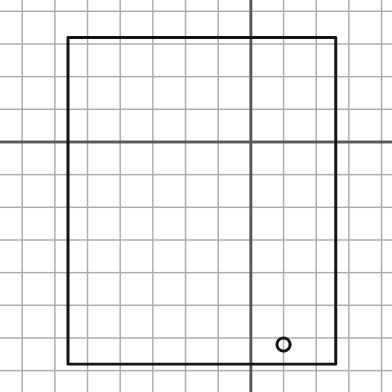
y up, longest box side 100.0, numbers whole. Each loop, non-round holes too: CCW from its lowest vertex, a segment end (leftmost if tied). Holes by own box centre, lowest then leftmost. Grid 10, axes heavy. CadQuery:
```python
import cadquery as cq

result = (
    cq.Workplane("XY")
    .moveTo(-56.0, -68.0)
    .lineTo(26.0, -68.0)
    .lineTo(26.0, 32.0)
    .lineTo(-56.0, 32.0)
    .close()
    .moveTo(10.0, -62.0)
    .circle(2.0)
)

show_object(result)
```